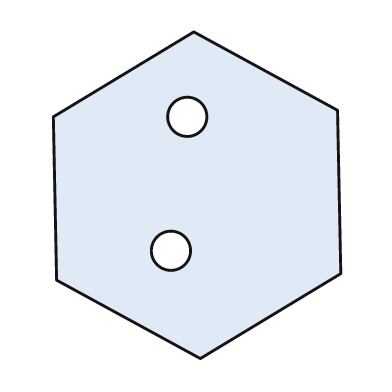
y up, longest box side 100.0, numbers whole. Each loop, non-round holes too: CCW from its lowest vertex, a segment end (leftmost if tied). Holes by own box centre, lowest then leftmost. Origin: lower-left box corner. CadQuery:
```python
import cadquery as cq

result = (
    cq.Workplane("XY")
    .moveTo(45.0, 0.0)
    .lineTo(88.0, 26.0)
    .lineTo(87.0, 76.0)
    .lineTo(43.0, 100.0)
    .lineTo(0.0, 74.0)
    .lineTo(1.0, 24.0)
    .close()
    .moveTo(36.0, 33.0)
    .circle(6.0)
    .moveTo(41.0, 74.0)
    .circle(6.0)
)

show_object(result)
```